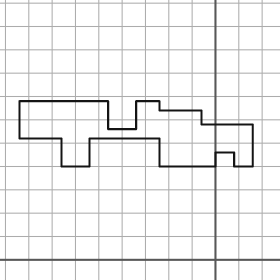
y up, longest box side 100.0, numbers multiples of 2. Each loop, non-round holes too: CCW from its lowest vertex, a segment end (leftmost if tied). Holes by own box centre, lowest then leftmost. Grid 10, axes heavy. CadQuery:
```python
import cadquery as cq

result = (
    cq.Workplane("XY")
    .moveTo(-66.0, 40.0)
    .lineTo(-54.0, 40.0)
    .lineTo(-54.0, 52.0)
    .lineTo(-24.0, 52.0)
    .lineTo(-24.0, 40.0)
    .lineTo(0.0, 40.0)
    .lineTo(0.0, 46.0)
    .lineTo(8.0, 46.0)
    .lineTo(8.0, 40.0)
    .lineTo(16.0, 40.0)
    .lineTo(16.0, 58.0)
    .lineTo(-6.0, 58.0)
    .lineTo(-6.0, 64.0)
    .lineTo(-24.0, 64.0)
    .lineTo(-24.0, 68.0)
    .lineTo(-34.0, 68.0)
    .lineTo(-34.0, 56.0)
    .lineTo(-46.0, 56.0)
    .lineTo(-46.0, 68.0)
    .lineTo(-84.0, 68.0)
    .lineTo(-84.0, 52.0)
    .lineTo(-66.0, 52.0)
    .close()
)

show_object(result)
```